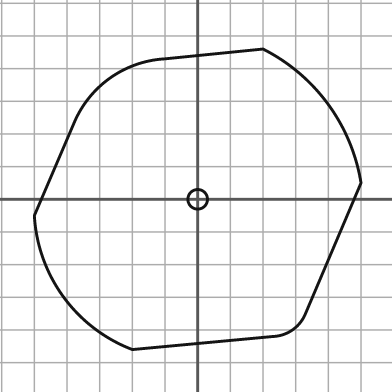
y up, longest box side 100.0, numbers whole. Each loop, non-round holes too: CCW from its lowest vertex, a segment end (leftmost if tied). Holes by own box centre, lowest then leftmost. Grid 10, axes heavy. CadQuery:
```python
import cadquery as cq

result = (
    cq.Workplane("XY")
    .moveTo(-20.0, -46.0)
    .lineTo(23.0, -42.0)
    .threePointArc((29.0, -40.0), (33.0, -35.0))
    .lineTo(50.0, 5.0)
    .threePointArc((40.0, 29.0), (20.0, 46.0))
    .lineTo(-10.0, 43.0)
    .threePointArc((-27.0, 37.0), (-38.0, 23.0))
    .lineTo(-50.0, -5.0)
    .threePointArc((-41.0, -30.0), (-20.0, -46.0))
    .close()
    .moveTo(0.0, 0.0)
    .circle(3.0)
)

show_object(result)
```